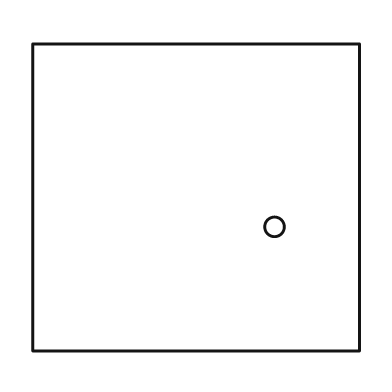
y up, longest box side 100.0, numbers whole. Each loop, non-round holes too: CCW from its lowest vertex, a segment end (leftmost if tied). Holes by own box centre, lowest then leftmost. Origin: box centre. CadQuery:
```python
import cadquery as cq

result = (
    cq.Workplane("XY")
    .moveTo(-50.0, -47.0)
    .lineTo(50.0, -47.0)
    .lineTo(50.0, 47.0)
    .lineTo(-50.0, 47.0)
    .close()
    .moveTo(24.0, -9.0)
    .circle(3.0)
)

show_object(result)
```